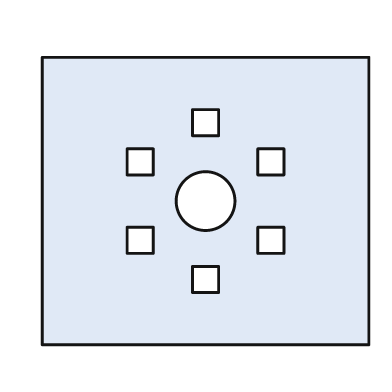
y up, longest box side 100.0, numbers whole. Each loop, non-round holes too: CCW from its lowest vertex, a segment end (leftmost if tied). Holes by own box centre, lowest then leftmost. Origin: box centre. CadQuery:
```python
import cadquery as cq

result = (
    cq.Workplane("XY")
    .moveTo(-50.0, -44.0)
    .lineTo(50.0, -44.0)
    .lineTo(50.0, 44.0)
    .lineTo(-50.0, 44.0)
    .close()
    .moveTo(-4.0, -28.0)
    .lineTo(4.0, -28.0)
    .lineTo(4.0, -20.0)
    .lineTo(-4.0, -20.0)
    .close()
    .moveTo(-24.0, -16.0)
    .lineTo(-16.0, -16.0)
    .lineTo(-16.0, -8.0)
    .lineTo(-24.0, -8.0)
    .close()
    .moveTo(16.0, -16.0)
    .lineTo(24.0, -16.0)
    .lineTo(24.0, -8.0)
    .lineTo(16.0, -8.0)
    .close()
    .moveTo(0.0, 0.0)
    .circle(9.0)
    .moveTo(-24.0, 8.0)
    .lineTo(-16.0, 8.0)
    .lineTo(-16.0, 16.0)
    .lineTo(-24.0, 16.0)
    .close()
    .moveTo(16.0, 8.0)
    .lineTo(24.0, 8.0)
    .lineTo(24.0, 16.0)
    .lineTo(16.0, 16.0)
    .close()
    .moveTo(-4.0, 20.0)
    .lineTo(4.0, 20.0)
    .lineTo(4.0, 28.0)
    .lineTo(-4.0, 28.0)
    .close()
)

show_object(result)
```